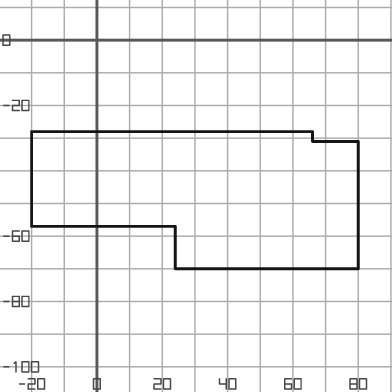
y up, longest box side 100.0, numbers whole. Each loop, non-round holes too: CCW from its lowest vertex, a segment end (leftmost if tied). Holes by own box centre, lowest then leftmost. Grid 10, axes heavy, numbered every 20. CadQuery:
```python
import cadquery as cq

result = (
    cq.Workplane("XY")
    .moveTo(24.0, -70.0)
    .lineTo(80.0, -70.0)
    .lineTo(80.0, -31.0)
    .lineTo(66.0, -31.0)
    .lineTo(66.0, -28.0)
    .lineTo(-20.0, -28.0)
    .lineTo(-20.0, -57.0)
    .lineTo(24.0, -57.0)
    .close()
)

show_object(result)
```